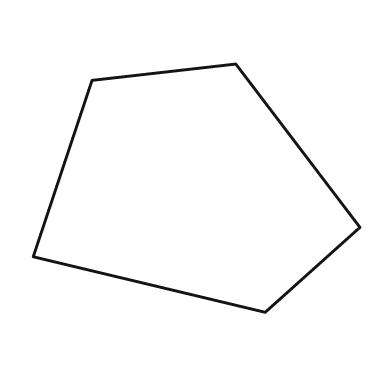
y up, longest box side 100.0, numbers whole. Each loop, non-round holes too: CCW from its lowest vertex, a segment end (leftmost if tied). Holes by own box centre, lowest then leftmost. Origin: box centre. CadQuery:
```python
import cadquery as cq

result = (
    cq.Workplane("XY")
    .moveTo(21.0, -38.0)
    .lineTo(50.0, -12.0)
    .lineTo(12.0, 38.0)
    .lineTo(-32.0, 33.0)
    .lineTo(-50.0, -21.0)
    .close()
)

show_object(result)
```